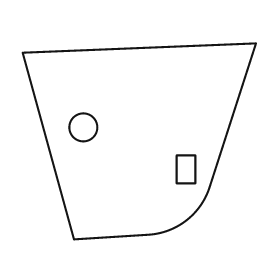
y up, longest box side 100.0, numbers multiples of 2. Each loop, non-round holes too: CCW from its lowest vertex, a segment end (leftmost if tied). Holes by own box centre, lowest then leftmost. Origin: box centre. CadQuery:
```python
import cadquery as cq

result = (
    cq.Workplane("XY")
    .moveTo(-28.0, -42.0)
    .lineTo(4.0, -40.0)
    .threePointArc((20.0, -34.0), (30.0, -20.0))
    .lineTo(50.0, 42.0)
    .lineTo(-50.0, 38.0)
    .close()
    .moveTo(16.0, -18.0)
    .lineTo(24.0, -18.0)
    .lineTo(24.0, -6.0)
    .lineTo(16.0, -6.0)
    .close()
    .moveTo(-24.0, 6.0)
    .circle(6.0)
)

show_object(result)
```